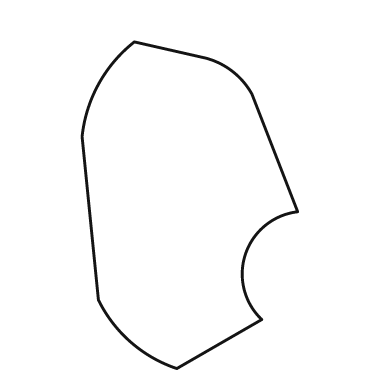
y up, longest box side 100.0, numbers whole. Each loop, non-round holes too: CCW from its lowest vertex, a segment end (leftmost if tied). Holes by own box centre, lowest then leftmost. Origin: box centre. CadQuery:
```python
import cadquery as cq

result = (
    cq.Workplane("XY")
    .moveTo(-4.0, -50.0)
    .lineTo(22.0, -35.0)
    .threePointArc((17.0, -15.0), (33.0, -2.0))
    .lineTo(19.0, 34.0)
    .threePointArc((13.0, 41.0), (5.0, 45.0))
    .lineTo(-17.0, 50.0)
    .threePointArc((-28.0, 37.0), (-33.0, 21.0))
    .lineTo(-28.0, -29.0)
    .threePointArc((-18.0, -42.0), (-4.0, -50.0))
    .close()
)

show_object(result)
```